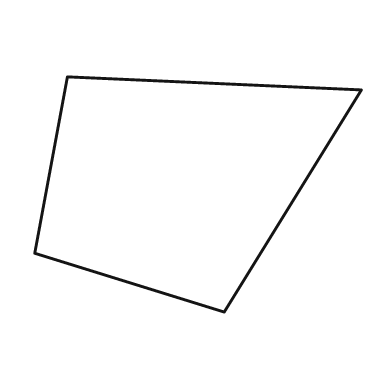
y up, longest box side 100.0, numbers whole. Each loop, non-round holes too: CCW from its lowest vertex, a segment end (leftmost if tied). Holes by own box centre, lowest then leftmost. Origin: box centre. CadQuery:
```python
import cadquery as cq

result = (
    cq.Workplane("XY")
    .moveTo(8.0, -36.0)
    .lineTo(50.0, 32.0)
    .lineTo(-40.0, 36.0)
    .lineTo(-50.0, -18.0)
    .close()
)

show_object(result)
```